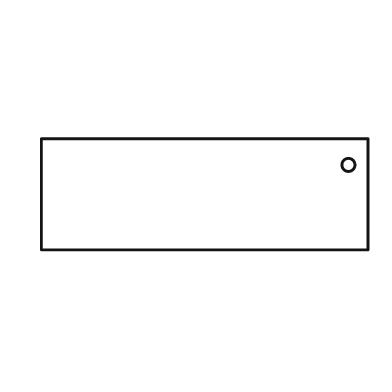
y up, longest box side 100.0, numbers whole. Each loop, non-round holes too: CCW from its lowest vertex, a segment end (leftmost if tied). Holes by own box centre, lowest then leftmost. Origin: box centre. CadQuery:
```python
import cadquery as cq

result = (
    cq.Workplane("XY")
    .moveTo(-50.0, -17.0)
    .lineTo(50.0, -17.0)
    .lineTo(50.0, 17.0)
    .lineTo(-50.0, 17.0)
    .close()
    .moveTo(44.0, 9.0)
    .circle(2.0)
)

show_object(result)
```